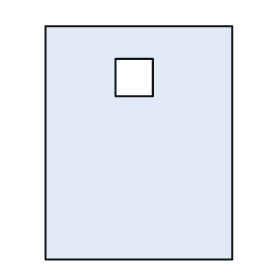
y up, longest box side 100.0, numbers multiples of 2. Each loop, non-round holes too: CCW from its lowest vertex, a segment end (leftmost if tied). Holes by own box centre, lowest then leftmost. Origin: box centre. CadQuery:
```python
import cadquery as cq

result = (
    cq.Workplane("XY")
    .moveTo(-40.0, -50.0)
    .lineTo(40.0, -50.0)
    .lineTo(40.0, 50.0)
    .lineTo(-40.0, 50.0)
    .close()
    .moveTo(-10.0, 20.0)
    .lineTo(6.0, 20.0)
    .lineTo(6.0, 36.0)
    .lineTo(-10.0, 36.0)
    .close()
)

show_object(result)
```